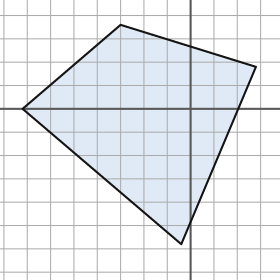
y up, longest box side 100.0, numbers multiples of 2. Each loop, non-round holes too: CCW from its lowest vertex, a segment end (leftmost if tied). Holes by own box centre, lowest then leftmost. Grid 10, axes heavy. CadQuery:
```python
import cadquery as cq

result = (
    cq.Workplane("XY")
    .moveTo(-4.0, -58.0)
    .lineTo(28.0, 18.0)
    .lineTo(-30.0, 36.0)
    .lineTo(-72.0, 0.0)
    .close()
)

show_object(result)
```